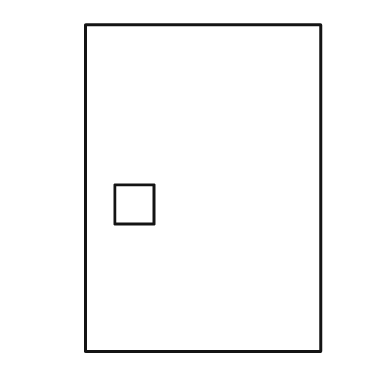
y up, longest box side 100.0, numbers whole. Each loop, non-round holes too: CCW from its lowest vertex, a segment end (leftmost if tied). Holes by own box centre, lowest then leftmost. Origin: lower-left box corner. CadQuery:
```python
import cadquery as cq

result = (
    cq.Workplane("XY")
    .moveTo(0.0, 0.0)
    .lineTo(72.0, 0.0)
    .lineTo(72.0, 100.0)
    .lineTo(0.0, 100.0)
    .close()
    .moveTo(9.0, 39.0)
    .lineTo(21.0, 39.0)
    .lineTo(21.0, 51.0)
    .lineTo(9.0, 51.0)
    .close()
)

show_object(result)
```